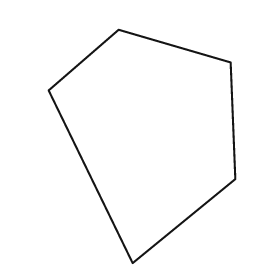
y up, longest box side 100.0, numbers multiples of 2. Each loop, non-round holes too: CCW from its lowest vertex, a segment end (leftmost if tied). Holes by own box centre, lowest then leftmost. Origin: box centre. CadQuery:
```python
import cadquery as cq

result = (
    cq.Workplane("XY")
    .moveTo(-4.0, -50.0)
    .lineTo(40.0, -14.0)
    .lineTo(38.0, 36.0)
    .lineTo(-10.0, 50.0)
    .lineTo(-40.0, 24.0)
    .close()
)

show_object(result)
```